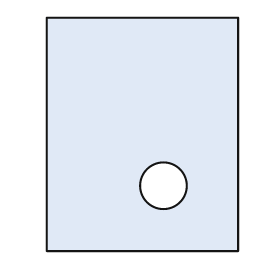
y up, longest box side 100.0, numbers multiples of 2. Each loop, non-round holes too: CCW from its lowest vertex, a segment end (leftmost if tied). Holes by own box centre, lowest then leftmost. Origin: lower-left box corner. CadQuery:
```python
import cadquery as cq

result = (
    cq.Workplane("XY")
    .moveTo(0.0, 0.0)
    .lineTo(82.0, 0.0)
    .lineTo(82.0, 100.0)
    .lineTo(0.0, 100.0)
    .close()
    .moveTo(50.0, 28.0)
    .circle(10.0)
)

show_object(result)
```